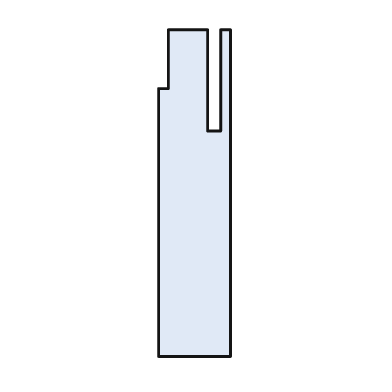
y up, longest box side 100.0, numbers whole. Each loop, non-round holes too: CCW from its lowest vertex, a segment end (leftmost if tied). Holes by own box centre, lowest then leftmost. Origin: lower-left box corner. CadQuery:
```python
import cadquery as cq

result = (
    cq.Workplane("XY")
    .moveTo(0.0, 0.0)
    .lineTo(22.0, 0.0)
    .lineTo(22.0, 100.0)
    .lineTo(19.0, 100.0)
    .lineTo(19.0, 69.0)
    .lineTo(15.0, 69.0)
    .lineTo(15.0, 100.0)
    .lineTo(3.0, 100.0)
    .lineTo(3.0, 82.0)
    .lineTo(0.0, 82.0)
    .close()
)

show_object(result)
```